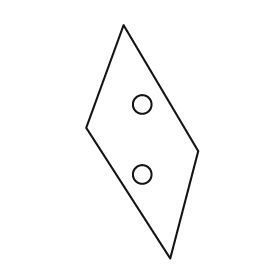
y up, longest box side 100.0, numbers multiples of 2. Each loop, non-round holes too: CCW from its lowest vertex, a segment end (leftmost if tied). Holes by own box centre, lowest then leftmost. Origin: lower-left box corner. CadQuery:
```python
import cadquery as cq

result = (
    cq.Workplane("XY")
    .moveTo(36.0, 0.0)
    .lineTo(48.0, 46.0)
    .lineTo(16.0, 100.0)
    .lineTo(0.0, 56.0)
    .close()
    .moveTo(24.0, 36.0)
    .circle(4.0)
    .moveTo(24.0, 66.0)
    .circle(4.0)
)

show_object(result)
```